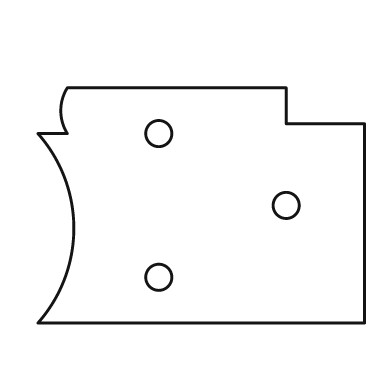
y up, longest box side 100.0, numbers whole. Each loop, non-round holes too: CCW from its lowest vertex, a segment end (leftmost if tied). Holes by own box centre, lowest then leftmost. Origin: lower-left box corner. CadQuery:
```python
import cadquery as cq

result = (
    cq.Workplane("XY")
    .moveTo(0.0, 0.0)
    .lineTo(100.0, 0.0)
    .lineTo(100.0, 61.0)
    .lineTo(76.0, 61.0)
    .lineTo(76.0, 72.0)
    .lineTo(9.0, 72.0)
    .threePointArc((7.0, 65.0), (9.0, 58.0))
    .lineTo(0.0, 58.0)
    .threePointArc((11.0, 29.0), (0.0, 0.0))
    .close()
    .moveTo(37.0, 14.0)
    .circle(4.0)
    .moveTo(76.0, 36.0)
    .circle(4.0)
    .moveTo(37.0, 58.0)
    .circle(4.0)
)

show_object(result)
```